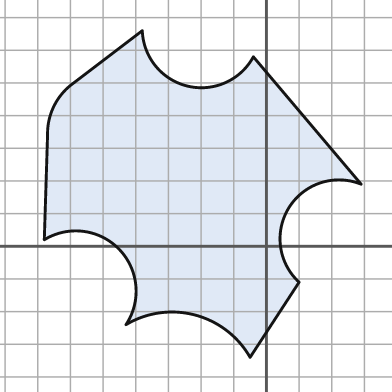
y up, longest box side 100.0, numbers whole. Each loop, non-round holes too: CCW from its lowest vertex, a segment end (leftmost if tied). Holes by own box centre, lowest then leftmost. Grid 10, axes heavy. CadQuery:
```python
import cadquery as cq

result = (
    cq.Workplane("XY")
    .moveTo(-5.0, -34.0)
    .lineTo(10.0, -11.0)
    .threePointArc((7.0, 12.0), (29.0, 19.0))
    .lineTo(-4.0, 58.0)
    .threePointArc((-24.0, 49.0), (-38.0, 66.0))
    .lineTo(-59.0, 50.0)
    .threePointArc((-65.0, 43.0), (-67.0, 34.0))
    .lineTo(-68.0, 2.0)
    .threePointArc((-45.0, -1.0), (-43.0, -24.0))
    .threePointArc((-22.0, -21.0), (-5.0, -34.0))
    .close()
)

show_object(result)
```